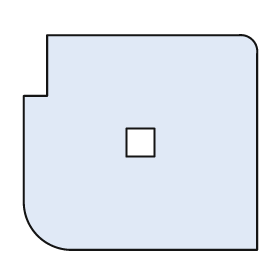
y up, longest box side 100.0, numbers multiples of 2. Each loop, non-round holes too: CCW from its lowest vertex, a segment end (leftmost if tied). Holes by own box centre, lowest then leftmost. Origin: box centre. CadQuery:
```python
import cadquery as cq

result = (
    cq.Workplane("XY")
    .moveTo(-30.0, -46.0)
    .lineTo(50.0, -46.0)
    .lineTo(50.0, 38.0)
    .threePointArc((48.0, 44.0), (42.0, 46.0))
    .lineTo(-40.0, 46.0)
    .lineTo(-40.0, 20.0)
    .lineTo(-50.0, 20.0)
    .lineTo(-50.0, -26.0)
    .threePointArc((-44.0, -40.0), (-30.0, -46.0))
    .close()
    .moveTo(-6.0, -6.0)
    .lineTo(6.0, -6.0)
    .lineTo(6.0, 6.0)
    .lineTo(-6.0, 6.0)
    .close()
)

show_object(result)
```